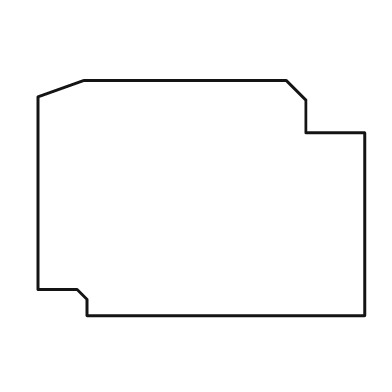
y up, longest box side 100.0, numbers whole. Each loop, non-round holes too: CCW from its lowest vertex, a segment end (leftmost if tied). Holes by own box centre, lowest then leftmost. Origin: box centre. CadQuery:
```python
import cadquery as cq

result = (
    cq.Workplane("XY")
    .moveTo(-35.0, -36.0)
    .lineTo(50.0, -36.0)
    .lineTo(50.0, 20.0)
    .lineTo(32.0, 20.0)
    .lineTo(32.0, 30.0)
    .lineTo(26.0, 36.0)
    .lineTo(-36.0, 36.0)
    .lineTo(-50.0, 31.0)
    .lineTo(-50.0, -28.0)
    .lineTo(-38.0, -28.0)
    .lineTo(-35.0, -31.0)
    .close()
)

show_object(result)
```